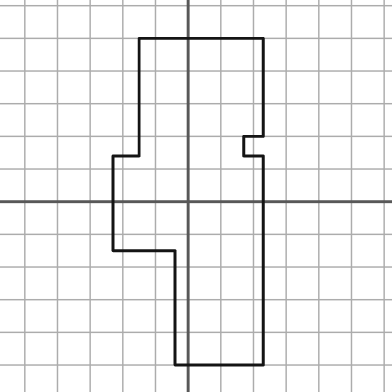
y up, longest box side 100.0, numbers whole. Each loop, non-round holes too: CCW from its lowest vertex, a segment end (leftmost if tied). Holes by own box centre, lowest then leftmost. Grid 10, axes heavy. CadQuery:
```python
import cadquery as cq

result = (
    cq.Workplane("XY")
    .moveTo(-4.0, -50.0)
    .lineTo(23.0, -50.0)
    .lineTo(23.0, 14.0)
    .lineTo(17.0, 14.0)
    .lineTo(17.0, 20.0)
    .lineTo(23.0, 20.0)
    .lineTo(23.0, 50.0)
    .lineTo(-15.0, 50.0)
    .lineTo(-15.0, 14.0)
    .lineTo(-23.0, 14.0)
    .lineTo(-23.0, -15.0)
    .lineTo(-4.0, -15.0)
    .close()
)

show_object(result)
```